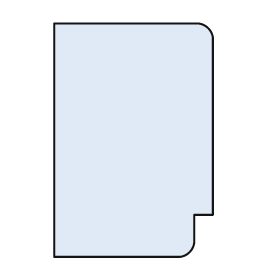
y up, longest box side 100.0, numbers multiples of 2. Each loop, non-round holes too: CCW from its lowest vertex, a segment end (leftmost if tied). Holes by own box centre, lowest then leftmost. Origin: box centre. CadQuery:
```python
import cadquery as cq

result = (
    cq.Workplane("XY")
    .moveTo(-34.0, -50.0)
    .lineTo(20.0, -50.0)
    .threePointArc((24.0, -48.0), (26.0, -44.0))
    .lineTo(26.0, -32.0)
    .lineTo(34.0, -32.0)
    .lineTo(34.0, 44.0)
    .threePointArc((32.0, 48.0), (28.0, 50.0))
    .lineTo(-34.0, 50.0)
    .close()
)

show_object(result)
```